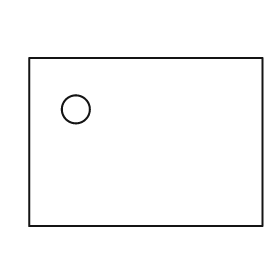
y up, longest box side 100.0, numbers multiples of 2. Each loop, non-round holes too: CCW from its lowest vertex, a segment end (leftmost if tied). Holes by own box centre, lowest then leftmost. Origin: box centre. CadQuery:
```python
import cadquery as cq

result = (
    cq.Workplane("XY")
    .moveTo(-50.0, -36.0)
    .lineTo(50.0, -36.0)
    .lineTo(50.0, 36.0)
    .lineTo(-50.0, 36.0)
    .close()
    .moveTo(-30.0, 14.0)
    .circle(6.0)
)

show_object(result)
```